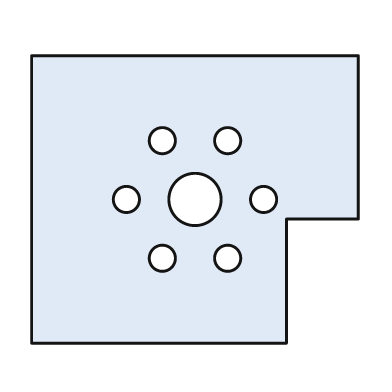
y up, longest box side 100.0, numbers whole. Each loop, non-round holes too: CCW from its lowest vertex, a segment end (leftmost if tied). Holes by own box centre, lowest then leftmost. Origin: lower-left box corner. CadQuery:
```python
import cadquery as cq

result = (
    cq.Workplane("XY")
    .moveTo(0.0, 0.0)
    .lineTo(78.0, 0.0)
    .lineTo(78.0, 38.0)
    .lineTo(100.0, 38.0)
    .lineTo(100.0, 88.0)
    .lineTo(0.0, 88.0)
    .close()
    .moveTo(40.0, 26.0)
    .circle(4.0)
    .moveTo(60.0, 26.0)
    .circle(4.0)
    .moveTo(29.0, 44.0)
    .circle(4.0)
    .moveTo(50.0, 44.0)
    .circle(8.0)
    .moveTo(71.0, 44.0)
    .circle(4.0)
    .moveTo(40.0, 62.0)
    .circle(4.0)
    .moveTo(60.0, 62.0)
    .circle(4.0)
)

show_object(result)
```